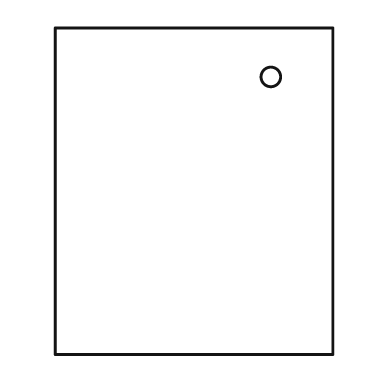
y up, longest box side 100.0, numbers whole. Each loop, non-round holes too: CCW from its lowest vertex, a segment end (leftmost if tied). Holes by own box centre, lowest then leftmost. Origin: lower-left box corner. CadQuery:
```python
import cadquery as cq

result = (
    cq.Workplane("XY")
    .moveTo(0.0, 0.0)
    .lineTo(85.0, 0.0)
    .lineTo(85.0, 100.0)
    .lineTo(0.0, 100.0)
    .close()
    .moveTo(66.0, 85.0)
    .circle(3.0)
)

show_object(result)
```